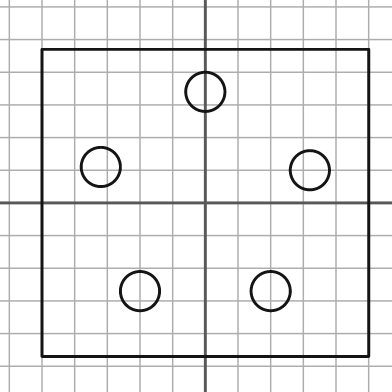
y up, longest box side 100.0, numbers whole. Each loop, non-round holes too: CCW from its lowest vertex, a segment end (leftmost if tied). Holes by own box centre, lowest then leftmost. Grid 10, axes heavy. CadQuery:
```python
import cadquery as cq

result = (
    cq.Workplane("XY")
    .moveTo(-50.0, -47.0)
    .lineTo(50.0, -47.0)
    .lineTo(50.0, 47.0)
    .lineTo(-50.0, 47.0)
    .close()
    .moveTo(-20.0, -27.0)
    .circle(6.0)
    .moveTo(20.0, -27.0)
    .circle(6.0)
    .moveTo(32.0, 10.0)
    .circle(6.0)
    .moveTo(-32.0, 11.0)
    .circle(6.0)
    .moveTo(0.0, 34.0)
    .circle(6.0)
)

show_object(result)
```